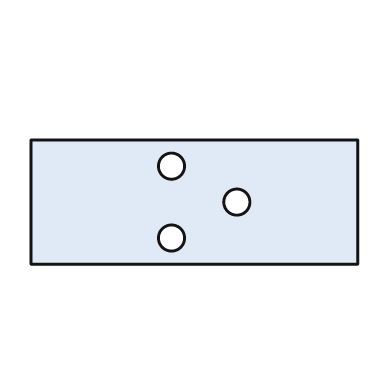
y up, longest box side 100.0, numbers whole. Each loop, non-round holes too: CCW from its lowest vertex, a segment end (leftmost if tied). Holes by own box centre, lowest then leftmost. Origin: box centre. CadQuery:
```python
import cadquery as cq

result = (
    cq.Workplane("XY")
    .moveTo(-50.0, -19.0)
    .lineTo(50.0, -19.0)
    .lineTo(50.0, 19.0)
    .lineTo(-50.0, 19.0)
    .close()
    .moveTo(-7.0, -11.0)
    .circle(4.0)
    .moveTo(13.0, 0.0)
    .circle(4.0)
    .moveTo(-7.0, 11.0)
    .circle(4.0)
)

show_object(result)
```